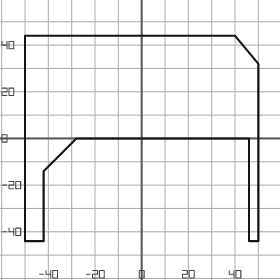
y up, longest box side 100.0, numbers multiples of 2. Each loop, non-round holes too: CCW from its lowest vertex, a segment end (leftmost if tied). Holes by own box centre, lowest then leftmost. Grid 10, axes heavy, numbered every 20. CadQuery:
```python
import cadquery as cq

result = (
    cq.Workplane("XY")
    .moveTo(-50.0, -44.0)
    .lineTo(-42.0, -44.0)
    .lineTo(-42.0, -14.0)
    .lineTo(-28.0, 0.0)
    .lineTo(46.0, 0.0)
    .lineTo(46.0, -44.0)
    .lineTo(50.0, -44.0)
    .lineTo(50.0, 32.0)
    .lineTo(40.0, 44.0)
    .lineTo(-50.0, 44.0)
    .close()
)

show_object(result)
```